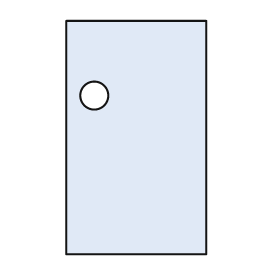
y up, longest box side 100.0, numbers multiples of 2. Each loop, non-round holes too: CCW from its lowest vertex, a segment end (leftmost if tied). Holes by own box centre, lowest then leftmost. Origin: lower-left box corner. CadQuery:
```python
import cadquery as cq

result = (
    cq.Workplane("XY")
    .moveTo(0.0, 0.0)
    .lineTo(60.0, 0.0)
    .lineTo(60.0, 100.0)
    .lineTo(0.0, 100.0)
    .close()
    .moveTo(12.0, 68.0)
    .circle(6.0)
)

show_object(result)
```